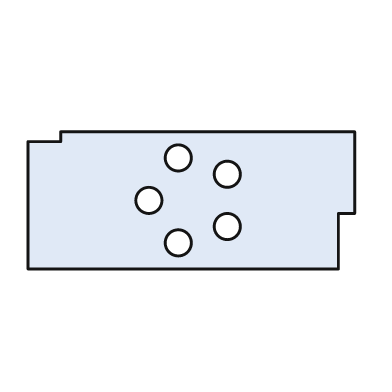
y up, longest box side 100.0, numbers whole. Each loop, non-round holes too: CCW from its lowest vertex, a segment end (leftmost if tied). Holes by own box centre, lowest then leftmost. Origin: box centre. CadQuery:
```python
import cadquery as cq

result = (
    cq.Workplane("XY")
    .moveTo(-50.0, -21.0)
    .lineTo(45.0, -21.0)
    .lineTo(45.0, -4.0)
    .lineTo(50.0, -4.0)
    .lineTo(50.0, 21.0)
    .lineTo(-40.0, 21.0)
    .lineTo(-40.0, 18.0)
    .lineTo(-50.0, 18.0)
    .close()
    .moveTo(-4.0, -13.0)
    .circle(4.0)
    .moveTo(11.0, -8.0)
    .circle(4.0)
    .moveTo(-13.0, 0.0)
    .circle(4.0)
    .moveTo(11.0, 8.0)
    .circle(4.0)
    .moveTo(-4.0, 13.0)
    .circle(4.0)
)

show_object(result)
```